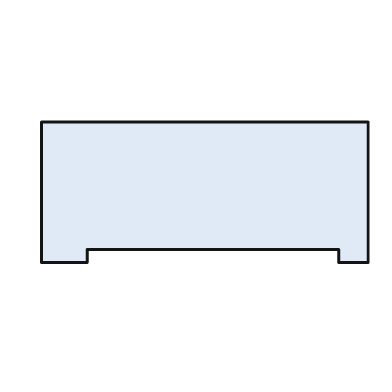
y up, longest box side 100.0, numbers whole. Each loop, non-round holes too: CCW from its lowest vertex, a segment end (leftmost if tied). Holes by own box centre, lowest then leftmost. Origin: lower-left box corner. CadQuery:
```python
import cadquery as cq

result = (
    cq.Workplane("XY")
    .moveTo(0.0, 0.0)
    .lineTo(14.0, 0.0)
    .lineTo(14.0, 4.0)
    .lineTo(91.0, 4.0)
    .lineTo(91.0, 0.0)
    .lineTo(100.0, 0.0)
    .lineTo(100.0, 43.0)
    .lineTo(0.0, 43.0)
    .close()
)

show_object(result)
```